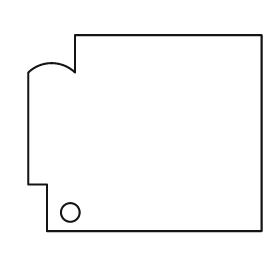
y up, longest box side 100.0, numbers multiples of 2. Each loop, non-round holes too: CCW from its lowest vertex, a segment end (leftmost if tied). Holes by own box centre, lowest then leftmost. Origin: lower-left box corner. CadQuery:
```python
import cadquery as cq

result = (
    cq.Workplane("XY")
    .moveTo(8.0, 0.0)
    .lineTo(100.0, 0.0)
    .lineTo(100.0, 84.0)
    .lineTo(20.0, 84.0)
    .lineTo(20.0, 68.0)
    .threePointArc((10.0, 72.0), (0.0, 68.0))
    .lineTo(0.0, 20.0)
    .lineTo(8.0, 20.0)
    .close()
    .moveTo(18.0, 8.0)
    .circle(4.0)
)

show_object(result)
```